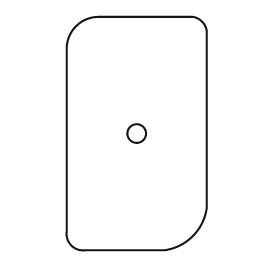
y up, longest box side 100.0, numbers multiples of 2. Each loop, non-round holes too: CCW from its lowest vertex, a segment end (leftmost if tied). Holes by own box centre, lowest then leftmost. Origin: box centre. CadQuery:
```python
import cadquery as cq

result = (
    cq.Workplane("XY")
    .moveTo(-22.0, -50.0)
    .lineTo(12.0, -50.0)
    .threePointArc((24.0, -44.0), (30.0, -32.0))
    .lineTo(30.0, 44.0)
    .threePointArc((28.0, 48.0), (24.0, 50.0))
    .lineTo(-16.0, 50.0)
    .threePointArc((-26.0, 46.0), (-30.0, 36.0))
    .lineTo(-30.0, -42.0)
    .threePointArc((-28.0, -48.0), (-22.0, -50.0))
    .close()
    .moveTo(0.0, 0.0)
    .circle(4.0)
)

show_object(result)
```